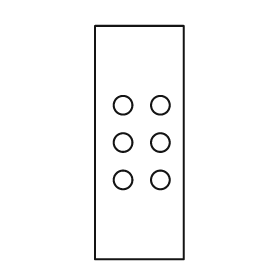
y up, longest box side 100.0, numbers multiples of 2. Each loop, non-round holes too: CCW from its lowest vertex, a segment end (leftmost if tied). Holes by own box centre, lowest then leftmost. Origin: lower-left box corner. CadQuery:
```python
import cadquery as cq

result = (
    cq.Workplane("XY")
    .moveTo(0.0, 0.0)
    .lineTo(38.0, 0.0)
    .lineTo(38.0, 100.0)
    .lineTo(0.0, 100.0)
    .close()
    .moveTo(12.0, 34.0)
    .circle(4.0)
    .moveTo(28.0, 34.0)
    .circle(4.0)
    .moveTo(12.0, 50.0)
    .circle(4.0)
    .moveTo(28.0, 50.0)
    .circle(4.0)
    .moveTo(12.0, 66.0)
    .circle(4.0)
    .moveTo(28.0, 66.0)
    .circle(4.0)
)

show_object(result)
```